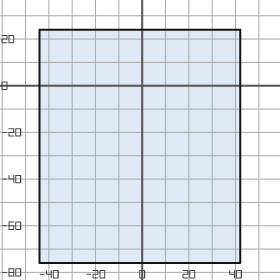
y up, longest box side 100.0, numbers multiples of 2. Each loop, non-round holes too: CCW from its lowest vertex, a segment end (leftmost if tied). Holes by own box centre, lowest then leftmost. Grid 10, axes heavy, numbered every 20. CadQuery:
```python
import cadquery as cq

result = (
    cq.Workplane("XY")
    .moveTo(-44.0, -76.0)
    .lineTo(42.0, -76.0)
    .lineTo(42.0, 24.0)
    .lineTo(-44.0, 24.0)
    .close()
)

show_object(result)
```